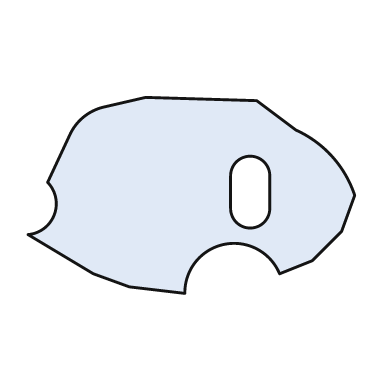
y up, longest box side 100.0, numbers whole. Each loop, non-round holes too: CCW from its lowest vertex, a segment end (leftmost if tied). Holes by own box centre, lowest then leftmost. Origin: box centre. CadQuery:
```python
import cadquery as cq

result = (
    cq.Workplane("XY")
    .moveTo(-2.0, -30.0)
    .threePointArc((10.0, -15.0), (27.0, -24.0))
    .lineTo(37.0, -20.0)
    .lineTo(46.0, -11.0)
    .lineTo(50.0, 0.0)
    .threePointArc((43.0, 12.0), (32.0, 20.0))
    .lineTo(20.0, 29.0)
    .lineTo(-14.0, 30.0)
    .lineTo(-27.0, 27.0)
    .threePointArc((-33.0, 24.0), (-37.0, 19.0))
    .lineTo(-44.0, 4.0)
    .threePointArc((-42.0, -6.0), (-50.0, -12.0))
    .lineTo(-30.0, -24.0)
    .lineTo(-19.0, -28.0)
    .close()
    .moveTo(12.0, -4.0)
    .threePointArc((18.0, -10.0), (24.0, -4.0))
    .lineTo(24.0, 6.0)
    .threePointArc((18.0, 12.0), (12.0, 6.0))
    .close()
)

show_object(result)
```